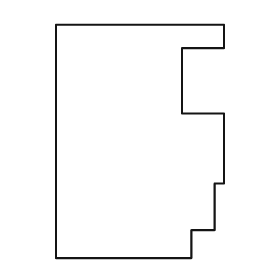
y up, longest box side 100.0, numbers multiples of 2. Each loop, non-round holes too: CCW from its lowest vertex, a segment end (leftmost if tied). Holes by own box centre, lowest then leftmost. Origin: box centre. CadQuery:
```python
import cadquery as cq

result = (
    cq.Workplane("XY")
    .moveTo(-36.0, -50.0)
    .lineTo(22.0, -50.0)
    .lineTo(22.0, -38.0)
    .lineTo(32.0, -38.0)
    .lineTo(32.0, -18.0)
    .lineTo(36.0, -18.0)
    .lineTo(36.0, 12.0)
    .lineTo(18.0, 12.0)
    .lineTo(18.0, 40.0)
    .lineTo(36.0, 40.0)
    .lineTo(36.0, 50.0)
    .lineTo(-36.0, 50.0)
    .close()
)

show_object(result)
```